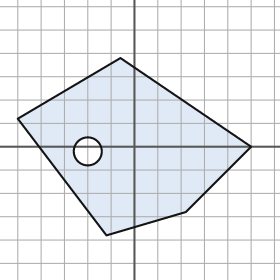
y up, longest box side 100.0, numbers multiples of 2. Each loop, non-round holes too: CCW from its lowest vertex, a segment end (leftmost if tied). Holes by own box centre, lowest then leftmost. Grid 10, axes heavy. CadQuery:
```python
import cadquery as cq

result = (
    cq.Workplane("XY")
    .moveTo(-12.0, -38.0)
    .lineTo(22.0, -28.0)
    .lineTo(50.0, 0.0)
    .lineTo(-6.0, 38.0)
    .lineTo(-50.0, 12.0)
    .close()
    .moveTo(-20.0, -2.0)
    .circle(6.0)
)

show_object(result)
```